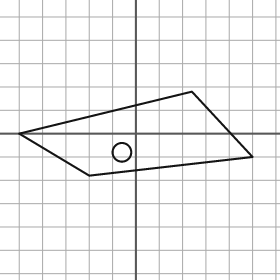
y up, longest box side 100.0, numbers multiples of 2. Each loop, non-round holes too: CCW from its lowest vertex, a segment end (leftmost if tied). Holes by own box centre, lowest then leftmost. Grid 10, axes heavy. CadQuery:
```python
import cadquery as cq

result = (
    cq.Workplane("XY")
    .moveTo(-20.0, -18.0)
    .lineTo(50.0, -10.0)
    .lineTo(24.0, 18.0)
    .lineTo(-50.0, 0.0)
    .close()
    .moveTo(-6.0, -8.0)
    .circle(4.0)
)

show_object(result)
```